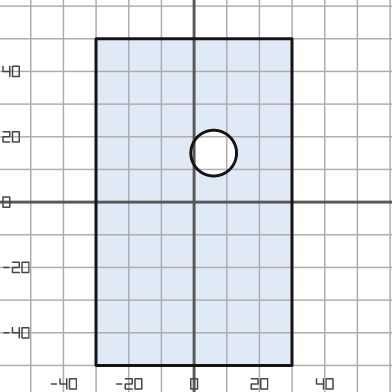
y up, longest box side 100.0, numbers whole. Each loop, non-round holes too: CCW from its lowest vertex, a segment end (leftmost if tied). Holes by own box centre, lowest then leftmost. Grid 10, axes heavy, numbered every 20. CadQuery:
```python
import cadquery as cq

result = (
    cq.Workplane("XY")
    .moveTo(-30.0, -50.0)
    .lineTo(30.0, -50.0)
    .lineTo(30.0, 50.0)
    .lineTo(-30.0, 50.0)
    .close()
    .moveTo(6.0, 15.0)
    .circle(7.0)
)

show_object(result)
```